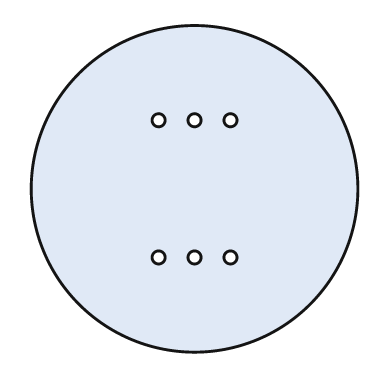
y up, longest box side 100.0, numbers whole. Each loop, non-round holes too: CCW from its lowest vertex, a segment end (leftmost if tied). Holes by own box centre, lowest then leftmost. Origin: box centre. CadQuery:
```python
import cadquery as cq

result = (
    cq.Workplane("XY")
    .moveTo(0.0, 0.0)
    .circle(50.0)
    .moveTo(-11.0, -21.0)
    .circle(2.0)
    .moveTo(0.0, -21.0)
    .circle(2.0)
    .moveTo(11.0, -21.0)
    .circle(2.0)
    .moveTo(-11.0, 21.0)
    .circle(2.0)
    .moveTo(0.0, 21.0)
    .circle(2.0)
    .moveTo(11.0, 21.0)
    .circle(2.0)
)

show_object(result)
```